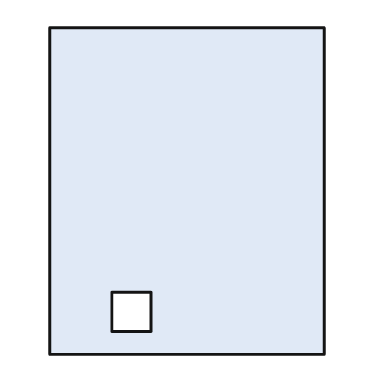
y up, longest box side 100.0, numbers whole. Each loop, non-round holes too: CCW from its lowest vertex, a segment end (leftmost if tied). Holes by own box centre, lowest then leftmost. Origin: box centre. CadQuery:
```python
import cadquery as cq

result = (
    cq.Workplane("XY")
    .moveTo(-42.0, -50.0)
    .lineTo(42.0, -50.0)
    .lineTo(42.0, 50.0)
    .lineTo(-42.0, 50.0)
    .close()
    .moveTo(-23.0, -43.0)
    .lineTo(-11.0, -43.0)
    .lineTo(-11.0, -31.0)
    .lineTo(-23.0, -31.0)
    .close()
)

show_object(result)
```